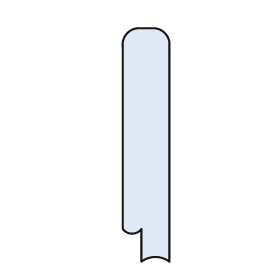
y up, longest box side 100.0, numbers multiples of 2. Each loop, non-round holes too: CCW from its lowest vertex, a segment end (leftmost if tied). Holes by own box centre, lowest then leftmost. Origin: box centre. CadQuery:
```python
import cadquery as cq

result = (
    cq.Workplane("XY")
    .moveTo(-2.0, -50.0)
    .threePointArc((4.0, -48.0), (10.0, -50.0))
    .lineTo(10.0, 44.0)
    .threePointArc((8.0, 48.0), (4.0, 50.0))
    .lineTo(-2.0, 50.0)
    .threePointArc((-8.0, 48.0), (-10.0, 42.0))
    .lineTo(-10.0, -36.0)
    .threePointArc((-6.0, -38.0), (-2.0, -36.0))
    .close()
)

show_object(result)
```